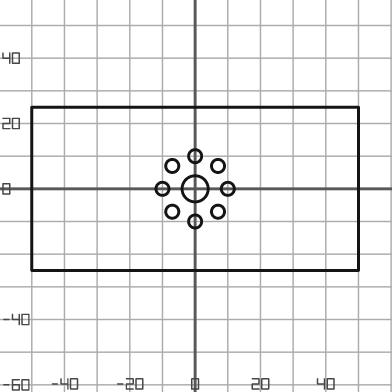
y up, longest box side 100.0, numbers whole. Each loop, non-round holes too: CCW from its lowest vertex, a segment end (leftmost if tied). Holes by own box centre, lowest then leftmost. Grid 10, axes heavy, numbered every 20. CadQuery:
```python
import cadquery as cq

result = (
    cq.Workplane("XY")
    .moveTo(-50.0, -25.0)
    .lineTo(50.0, -25.0)
    .lineTo(50.0, 25.0)
    .lineTo(-50.0, 25.0)
    .close()
    .moveTo(0.0, -10.0)
    .circle(2.0)
    .moveTo(-7.0, -7.0)
    .circle(2.0)
    .moveTo(7.0, -7.0)
    .circle(2.0)
    .moveTo(-10.0, 0.0)
    .circle(2.0)
    .moveTo(0.0, 0.0)
    .circle(4.0)
    .moveTo(10.0, 0.0)
    .circle(2.0)
    .moveTo(-7.0, 7.0)
    .circle(2.0)
    .moveTo(7.0, 7.0)
    .circle(2.0)
    .moveTo(0.0, 10.0)
    .circle(2.0)
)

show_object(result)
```